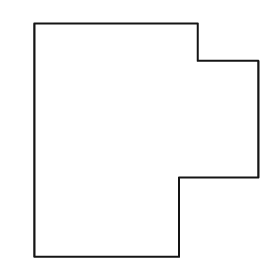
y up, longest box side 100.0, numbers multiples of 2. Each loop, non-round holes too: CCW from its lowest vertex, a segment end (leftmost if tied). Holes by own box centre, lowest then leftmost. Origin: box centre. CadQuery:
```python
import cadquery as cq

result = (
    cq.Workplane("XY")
    .moveTo(-48.0, -50.0)
    .lineTo(14.0, -50.0)
    .lineTo(14.0, -16.0)
    .lineTo(48.0, -16.0)
    .lineTo(48.0, 34.0)
    .lineTo(22.0, 34.0)
    .lineTo(22.0, 50.0)
    .lineTo(-48.0, 50.0)
    .close()
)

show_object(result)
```